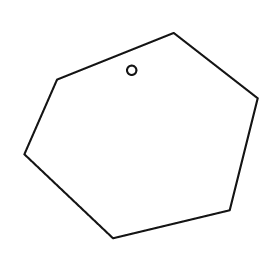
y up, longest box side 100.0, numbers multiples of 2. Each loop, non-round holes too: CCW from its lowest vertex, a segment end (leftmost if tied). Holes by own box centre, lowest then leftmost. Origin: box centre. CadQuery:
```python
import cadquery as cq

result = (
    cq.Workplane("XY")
    .moveTo(-12.0, -44.0)
    .lineTo(38.0, -32.0)
    .lineTo(50.0, 16.0)
    .lineTo(14.0, 44.0)
    .lineTo(-36.0, 24.0)
    .lineTo(-50.0, -8.0)
    .close()
    .moveTo(-4.0, 28.0)
    .circle(2.0)
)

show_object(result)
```